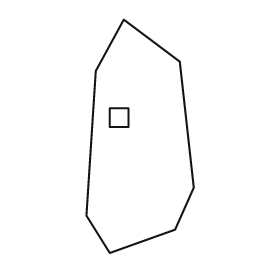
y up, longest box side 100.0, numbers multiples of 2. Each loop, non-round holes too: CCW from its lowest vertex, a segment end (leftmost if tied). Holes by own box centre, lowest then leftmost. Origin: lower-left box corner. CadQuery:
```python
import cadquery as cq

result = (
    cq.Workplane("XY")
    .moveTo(10.0, 0.0)
    .lineTo(38.0, 10.0)
    .lineTo(46.0, 28.0)
    .lineTo(40.0, 82.0)
    .lineTo(16.0, 100.0)
    .lineTo(4.0, 78.0)
    .lineTo(0.0, 16.0)
    .close()
    .moveTo(10.0, 54.0)
    .lineTo(18.0, 54.0)
    .lineTo(18.0, 62.0)
    .lineTo(10.0, 62.0)
    .close()
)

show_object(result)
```